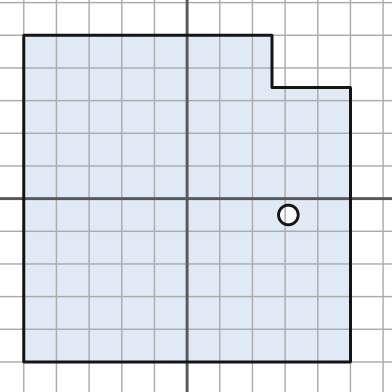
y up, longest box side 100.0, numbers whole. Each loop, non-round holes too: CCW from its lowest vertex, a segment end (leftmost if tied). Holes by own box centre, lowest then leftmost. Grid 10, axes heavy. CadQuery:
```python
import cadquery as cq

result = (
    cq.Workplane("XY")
    .moveTo(-50.0, -50.0)
    .lineTo(50.0, -50.0)
    .lineTo(50.0, 34.0)
    .lineTo(26.0, 34.0)
    .lineTo(26.0, 50.0)
    .lineTo(-50.0, 50.0)
    .close()
    .moveTo(31.0, -5.0)
    .circle(3.0)
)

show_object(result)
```